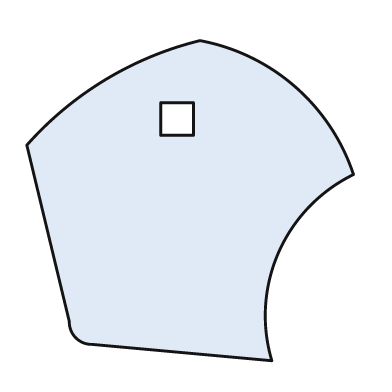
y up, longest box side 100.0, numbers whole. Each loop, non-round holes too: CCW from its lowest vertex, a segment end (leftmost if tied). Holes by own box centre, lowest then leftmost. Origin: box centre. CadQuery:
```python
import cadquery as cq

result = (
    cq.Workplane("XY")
    .moveTo(25.0, -49.0)
    .threePointArc((27.0, -16.0), (50.0, 8.0))
    .threePointArc((32.0, 35.0), (3.0, 49.0))
    .threePointArc((-26.0, 37.0), (-50.0, 17.0))
    .lineTo(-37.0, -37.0)
    .threePointArc((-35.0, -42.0), (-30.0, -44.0))
    .close()
    .moveTo(-9.0, 20.0)
    .lineTo(1.0, 20.0)
    .lineTo(1.0, 30.0)
    .lineTo(-9.0, 30.0)
    .close()
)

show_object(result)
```